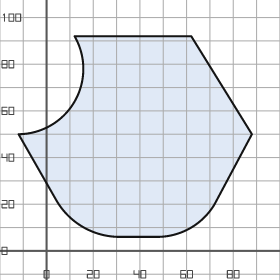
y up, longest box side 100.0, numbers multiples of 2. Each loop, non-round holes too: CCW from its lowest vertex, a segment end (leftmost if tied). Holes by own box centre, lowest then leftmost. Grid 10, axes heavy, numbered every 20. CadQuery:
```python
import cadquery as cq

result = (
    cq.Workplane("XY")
    .moveTo(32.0, 6.0)
    .lineTo(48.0, 6.0)
    .threePointArc((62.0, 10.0), (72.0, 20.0))
    .lineTo(88.0, 50.0)
    .lineTo(62.0, 92.0)
    .lineTo(12.0, 92.0)
    .threePointArc((12.0, 64.0), (-12.0, 50.0))
    .lineTo(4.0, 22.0)
    .threePointArc((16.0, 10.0), (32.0, 6.0))
    .close()
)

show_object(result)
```